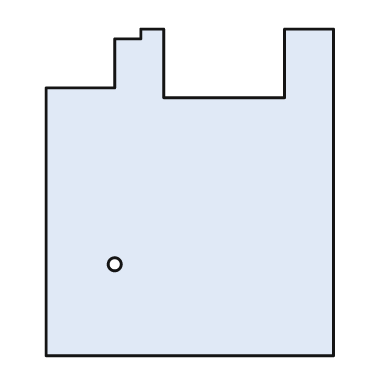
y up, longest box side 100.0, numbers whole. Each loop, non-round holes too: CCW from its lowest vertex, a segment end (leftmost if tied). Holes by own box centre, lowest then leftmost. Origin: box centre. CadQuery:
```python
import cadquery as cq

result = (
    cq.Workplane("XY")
    .moveTo(-44.0, -50.0)
    .lineTo(44.0, -50.0)
    .lineTo(44.0, 50.0)
    .lineTo(29.0, 50.0)
    .lineTo(29.0, 29.0)
    .lineTo(-8.0, 29.0)
    .lineTo(-8.0, 50.0)
    .lineTo(-15.0, 50.0)
    .lineTo(-15.0, 47.0)
    .lineTo(-23.0, 47.0)
    .lineTo(-23.0, 32.0)
    .lineTo(-44.0, 32.0)
    .close()
    .moveTo(-23.0, -22.0)
    .circle(2.0)
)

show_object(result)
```